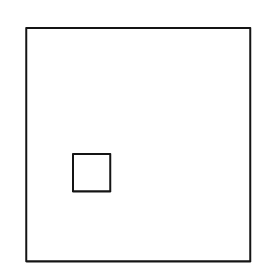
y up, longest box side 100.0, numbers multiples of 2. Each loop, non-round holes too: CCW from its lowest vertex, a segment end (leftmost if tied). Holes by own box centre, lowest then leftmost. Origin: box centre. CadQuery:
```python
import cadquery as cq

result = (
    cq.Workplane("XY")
    .moveTo(-48.0, -50.0)
    .lineTo(48.0, -50.0)
    .lineTo(48.0, 50.0)
    .lineTo(-48.0, 50.0)
    .close()
    .moveTo(-28.0, -20.0)
    .lineTo(-12.0, -20.0)
    .lineTo(-12.0, -4.0)
    .lineTo(-28.0, -4.0)
    .close()
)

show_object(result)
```